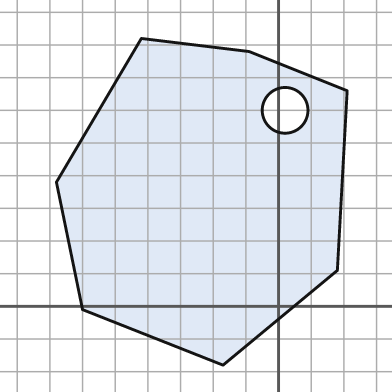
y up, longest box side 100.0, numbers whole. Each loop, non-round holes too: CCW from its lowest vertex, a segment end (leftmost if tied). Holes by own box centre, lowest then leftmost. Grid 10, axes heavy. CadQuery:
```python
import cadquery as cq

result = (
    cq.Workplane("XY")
    .moveTo(-17.0, -18.0)
    .lineTo(18.0, 11.0)
    .lineTo(21.0, 66.0)
    .lineTo(-9.0, 78.0)
    .lineTo(-42.0, 82.0)
    .lineTo(-68.0, 38.0)
    .lineTo(-60.0, -1.0)
    .close()
    .moveTo(2.0, 60.0)
    .circle(7.0)
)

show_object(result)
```